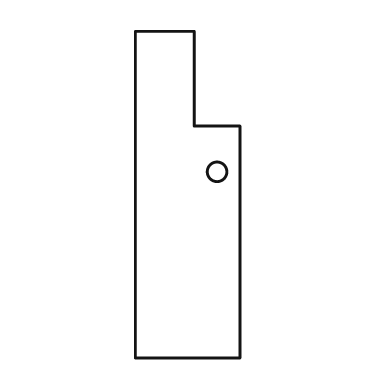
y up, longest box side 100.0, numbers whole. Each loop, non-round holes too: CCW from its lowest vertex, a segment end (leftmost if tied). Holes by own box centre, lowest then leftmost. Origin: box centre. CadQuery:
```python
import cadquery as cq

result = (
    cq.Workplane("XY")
    .moveTo(-16.0, -50.0)
    .lineTo(16.0, -50.0)
    .lineTo(16.0, 21.0)
    .lineTo(2.0, 21.0)
    .lineTo(2.0, 50.0)
    .lineTo(-16.0, 50.0)
    .close()
    .moveTo(9.0, 7.0)
    .circle(3.0)
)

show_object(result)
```